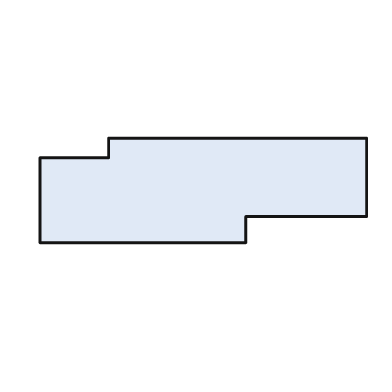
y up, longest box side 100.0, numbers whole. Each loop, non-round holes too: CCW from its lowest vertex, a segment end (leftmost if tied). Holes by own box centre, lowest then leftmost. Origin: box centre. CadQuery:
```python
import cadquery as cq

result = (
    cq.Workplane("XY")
    .moveTo(-50.0, -16.0)
    .lineTo(13.0, -16.0)
    .lineTo(13.0, -8.0)
    .lineTo(50.0, -8.0)
    .lineTo(50.0, 16.0)
    .lineTo(-29.0, 16.0)
    .lineTo(-29.0, 10.0)
    .lineTo(-50.0, 10.0)
    .close()
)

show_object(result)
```